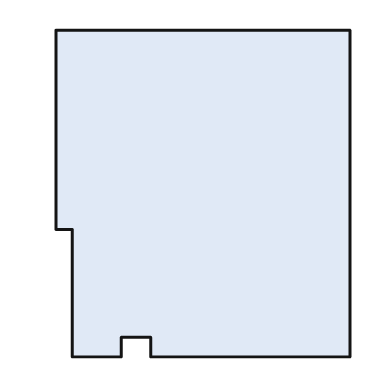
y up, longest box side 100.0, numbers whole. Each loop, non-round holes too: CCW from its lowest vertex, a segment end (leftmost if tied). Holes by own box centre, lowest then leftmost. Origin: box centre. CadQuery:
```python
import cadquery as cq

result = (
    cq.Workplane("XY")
    .moveTo(-40.0, -50.0)
    .lineTo(-25.0, -50.0)
    .lineTo(-25.0, -44.0)
    .lineTo(-16.0, -44.0)
    .lineTo(-16.0, -50.0)
    .lineTo(45.0, -50.0)
    .lineTo(45.0, 50.0)
    .lineTo(-45.0, 50.0)
    .lineTo(-45.0, -11.0)
    .lineTo(-40.0, -11.0)
    .close()
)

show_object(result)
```